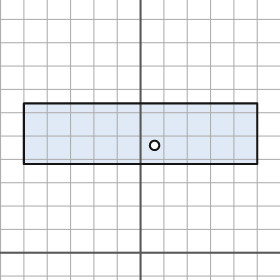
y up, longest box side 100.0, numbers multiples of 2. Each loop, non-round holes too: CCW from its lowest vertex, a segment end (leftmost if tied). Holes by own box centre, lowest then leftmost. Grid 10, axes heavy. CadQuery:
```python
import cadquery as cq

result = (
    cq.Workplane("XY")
    .moveTo(-50.0, 38.0)
    .lineTo(50.0, 38.0)
    .lineTo(50.0, 64.0)
    .lineTo(-50.0, 64.0)
    .close()
    .moveTo(6.0, 46.0)
    .circle(2.0)
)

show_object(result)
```